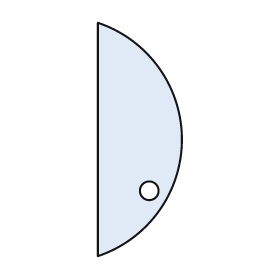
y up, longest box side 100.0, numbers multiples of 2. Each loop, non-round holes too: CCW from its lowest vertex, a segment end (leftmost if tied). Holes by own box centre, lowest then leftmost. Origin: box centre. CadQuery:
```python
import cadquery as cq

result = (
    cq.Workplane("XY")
    .moveTo(-18.0, -50.0)
    .threePointArc((18.0, 0.0), (-18.0, 50.0))
    .close()
    .moveTo(4.0, -22.0)
    .circle(4.0)
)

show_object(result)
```